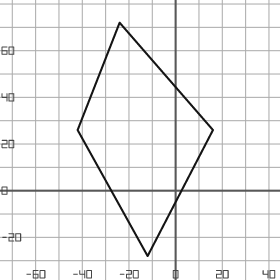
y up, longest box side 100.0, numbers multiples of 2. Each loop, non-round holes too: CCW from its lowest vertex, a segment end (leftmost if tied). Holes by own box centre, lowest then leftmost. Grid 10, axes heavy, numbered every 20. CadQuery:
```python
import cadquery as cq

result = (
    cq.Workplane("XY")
    .moveTo(-12.0, -28.0)
    .lineTo(16.0, 26.0)
    .lineTo(-24.0, 72.0)
    .lineTo(-42.0, 26.0)
    .close()
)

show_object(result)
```